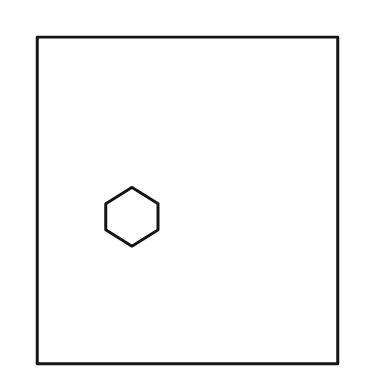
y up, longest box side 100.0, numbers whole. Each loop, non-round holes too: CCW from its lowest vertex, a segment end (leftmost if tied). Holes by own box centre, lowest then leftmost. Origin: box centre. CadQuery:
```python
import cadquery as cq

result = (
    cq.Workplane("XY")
    .moveTo(-46.0, -50.0)
    .lineTo(46.0, -50.0)
    .lineTo(46.0, 50.0)
    .lineTo(-46.0, 50.0)
    .close()
    .moveTo(-17.0, -14.0)
    .lineTo(-9.0, -9.0)
    .lineTo(-9.0, -1.0)
    .lineTo(-17.0, 4.0)
    .lineTo(-25.0, -1.0)
    .lineTo(-25.0, -9.0)
    .close()
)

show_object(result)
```